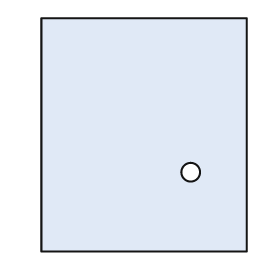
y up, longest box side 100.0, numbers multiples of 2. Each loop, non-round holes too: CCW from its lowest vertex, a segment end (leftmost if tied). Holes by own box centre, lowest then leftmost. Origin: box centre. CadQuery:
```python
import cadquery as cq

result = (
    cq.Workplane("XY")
    .moveTo(-44.0, -50.0)
    .lineTo(44.0, -50.0)
    .lineTo(44.0, 50.0)
    .lineTo(-44.0, 50.0)
    .close()
    .moveTo(20.0, -16.0)
    .circle(4.0)
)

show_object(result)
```